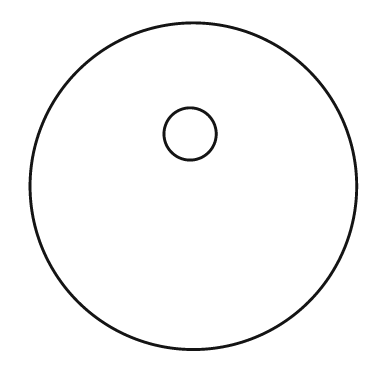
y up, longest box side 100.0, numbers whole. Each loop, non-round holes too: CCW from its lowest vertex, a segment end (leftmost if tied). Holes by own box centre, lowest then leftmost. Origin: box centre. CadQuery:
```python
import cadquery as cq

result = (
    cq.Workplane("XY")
    .moveTo(0.0, 0.0)
    .circle(50.0)
    .moveTo(-1.0, 16.0)
    .circle(8.0)
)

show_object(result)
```